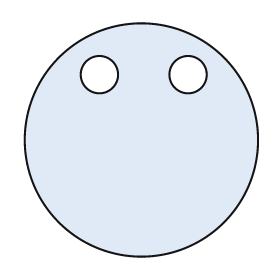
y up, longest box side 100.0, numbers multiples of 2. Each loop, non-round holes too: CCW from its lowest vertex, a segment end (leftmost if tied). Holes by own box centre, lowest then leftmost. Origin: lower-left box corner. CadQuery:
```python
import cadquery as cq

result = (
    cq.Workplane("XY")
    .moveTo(50.0, 50.0)
    .circle(50.0)
    .moveTo(32.0, 78.0)
    .circle(8.0)
    .moveTo(70.0, 78.0)
    .circle(8.0)
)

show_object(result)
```